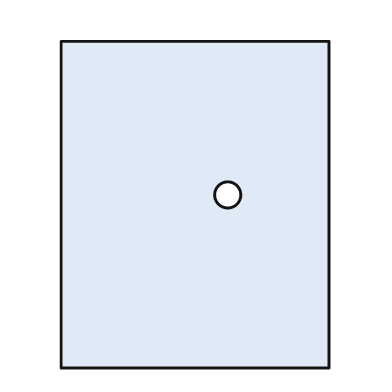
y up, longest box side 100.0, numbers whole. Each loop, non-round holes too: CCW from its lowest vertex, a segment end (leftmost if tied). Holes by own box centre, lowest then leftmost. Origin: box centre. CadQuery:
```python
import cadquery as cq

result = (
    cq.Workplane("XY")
    .moveTo(-41.0, -50.0)
    .lineTo(41.0, -50.0)
    .lineTo(41.0, 50.0)
    .lineTo(-41.0, 50.0)
    .close()
    .moveTo(10.0, 3.0)
    .circle(4.0)
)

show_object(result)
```